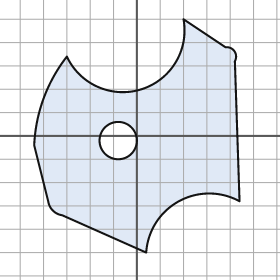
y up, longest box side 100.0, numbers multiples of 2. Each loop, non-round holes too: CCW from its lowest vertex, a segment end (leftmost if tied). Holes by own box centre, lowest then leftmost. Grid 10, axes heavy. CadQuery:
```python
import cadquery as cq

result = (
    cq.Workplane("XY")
    .moveTo(4.0, -50.0)
    .threePointArc((18.0, -28.0), (44.0, -28.0))
    .lineTo(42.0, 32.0)
    .threePointArc((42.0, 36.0), (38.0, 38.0))
    .lineTo(20.0, 50.0)
    .threePointArc((2.0, 20.0), (-30.0, 34.0))
    .threePointArc((-40.0, 16.0), (-44.0, -4.0))
    .lineTo(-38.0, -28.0)
    .threePointArc((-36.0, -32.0), (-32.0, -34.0))
    .close()
    .moveTo(-8.0, -2.0)
    .circle(8.0)
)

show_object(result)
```